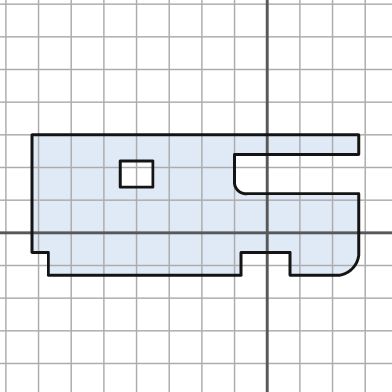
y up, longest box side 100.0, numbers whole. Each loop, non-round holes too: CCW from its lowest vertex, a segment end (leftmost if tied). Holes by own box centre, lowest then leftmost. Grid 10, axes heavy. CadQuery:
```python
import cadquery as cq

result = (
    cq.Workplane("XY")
    .moveTo(-67.0, -13.0)
    .lineTo(-8.0, -13.0)
    .lineTo(-8.0, -6.0)
    .lineTo(7.0, -6.0)
    .lineTo(7.0, -13.0)
    .lineTo(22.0, -13.0)
    .threePointArc((26.0, -11.0), (28.0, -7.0))
    .lineTo(28.0, 12.0)
    .lineTo(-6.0, 12.0)
    .threePointArc((-9.0, 13.0), (-10.0, 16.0))
    .lineTo(-10.0, 24.0)
    .lineTo(28.0, 24.0)
    .lineTo(28.0, 30.0)
    .lineTo(-72.0, 30.0)
    .lineTo(-72.0, -6.0)
    .lineTo(-67.0, -6.0)
    .close()
    .moveTo(-45.0, 14.0)
    .lineTo(-35.0, 14.0)
    .lineTo(-35.0, 22.0)
    .lineTo(-45.0, 22.0)
    .close()
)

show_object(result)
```